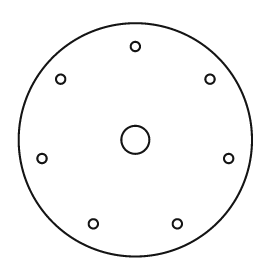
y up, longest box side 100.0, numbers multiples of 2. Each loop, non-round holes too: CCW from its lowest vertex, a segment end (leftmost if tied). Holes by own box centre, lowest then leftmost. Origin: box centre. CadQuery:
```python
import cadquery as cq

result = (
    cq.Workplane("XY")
    .moveTo(0.0, 0.0)
    .circle(50.0)
    .moveTo(-18.0, -36.0)
    .circle(2.0)
    .moveTo(18.0, -36.0)
    .circle(2.0)
    .moveTo(-40.0, -8.0)
    .circle(2.0)
    .moveTo(40.0, -8.0)
    .circle(2.0)
    .moveTo(0.0, 0.0)
    .circle(6.0)
    .moveTo(-32.0, 26.0)
    .circle(2.0)
    .moveTo(32.0, 26.0)
    .circle(2.0)
    .moveTo(0.0, 40.0)
    .circle(2.0)
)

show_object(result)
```